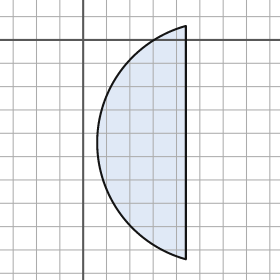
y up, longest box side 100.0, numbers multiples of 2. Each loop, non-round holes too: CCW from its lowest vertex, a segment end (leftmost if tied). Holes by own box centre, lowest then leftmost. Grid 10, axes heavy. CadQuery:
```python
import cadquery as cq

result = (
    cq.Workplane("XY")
    .moveTo(44.0, -94.0)
    .lineTo(44.0, 6.0)
    .threePointArc((6.0, -44.0), (44.0, -94.0))
    .close()
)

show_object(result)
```